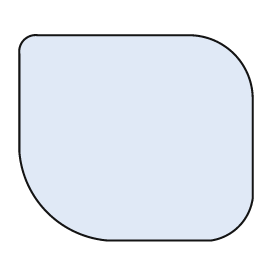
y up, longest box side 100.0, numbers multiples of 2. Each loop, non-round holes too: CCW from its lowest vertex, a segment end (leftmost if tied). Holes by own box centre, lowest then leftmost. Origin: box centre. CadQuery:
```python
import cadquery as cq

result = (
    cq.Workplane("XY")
    .moveTo(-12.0, -44.0)
    .lineTo(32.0, -44.0)
    .threePointArc((44.0, -38.0), (50.0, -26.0))
    .lineTo(50.0, 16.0)
    .threePointArc((42.0, 36.0), (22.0, 44.0))
    .lineTo(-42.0, 44.0)
    .threePointArc((-48.0, 42.0), (-50.0, 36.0))
    .lineTo(-50.0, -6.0)
    .threePointArc((-38.0, -32.0), (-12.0, -44.0))
    .close()
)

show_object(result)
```